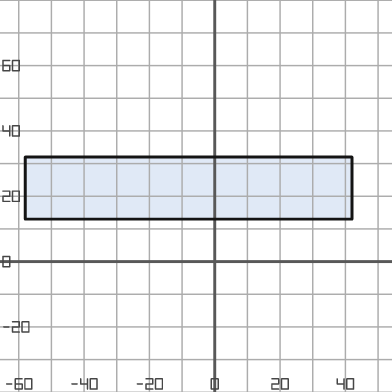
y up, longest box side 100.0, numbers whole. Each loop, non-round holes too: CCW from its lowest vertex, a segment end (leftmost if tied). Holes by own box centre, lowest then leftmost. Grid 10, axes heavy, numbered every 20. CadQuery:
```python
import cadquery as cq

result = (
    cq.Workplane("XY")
    .moveTo(-58.0, 13.0)
    .lineTo(42.0, 13.0)
    .lineTo(42.0, 32.0)
    .lineTo(-58.0, 32.0)
    .close()
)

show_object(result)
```